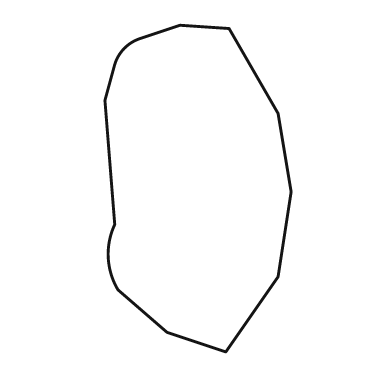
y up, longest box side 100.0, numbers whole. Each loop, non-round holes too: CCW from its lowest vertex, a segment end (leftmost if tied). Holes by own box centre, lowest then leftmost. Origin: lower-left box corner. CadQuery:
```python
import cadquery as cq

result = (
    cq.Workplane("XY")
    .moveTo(37.0, 0.0)
    .lineTo(53.0, 23.0)
    .lineTo(57.0, 49.0)
    .lineTo(53.0, 73.0)
    .lineTo(38.0, 99.0)
    .lineTo(23.0, 100.0)
    .lineTo(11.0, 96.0)
    .threePointArc((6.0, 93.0), (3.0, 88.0))
    .lineTo(0.0, 77.0)
    .lineTo(3.0, 39.0)
    .threePointArc((1.0, 29.0), (4.0, 19.0))
    .lineTo(19.0, 6.0)
    .close()
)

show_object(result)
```